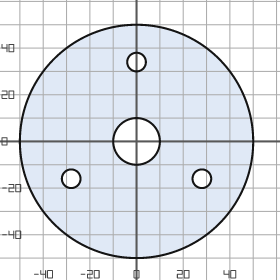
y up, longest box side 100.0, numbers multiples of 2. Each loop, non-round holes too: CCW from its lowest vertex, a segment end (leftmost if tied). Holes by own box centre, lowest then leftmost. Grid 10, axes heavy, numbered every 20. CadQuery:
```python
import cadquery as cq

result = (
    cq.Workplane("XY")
    .moveTo(0.0, 0.0)
    .circle(50.0)
    .moveTo(-28.0, -16.0)
    .circle(4.0)
    .moveTo(28.0, -16.0)
    .circle(4.0)
    .moveTo(0.0, 0.0)
    .circle(10.0)
    .moveTo(0.0, 34.0)
    .circle(4.0)
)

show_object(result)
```